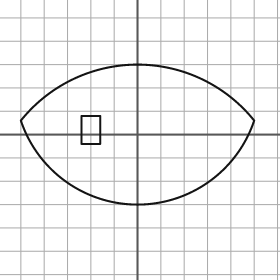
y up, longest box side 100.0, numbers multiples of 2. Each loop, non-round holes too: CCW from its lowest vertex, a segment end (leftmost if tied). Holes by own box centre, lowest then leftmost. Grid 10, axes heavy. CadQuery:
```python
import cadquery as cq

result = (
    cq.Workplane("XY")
    .moveTo(-50.0, 6.0)
    .threePointArc((0.0, -30.0), (50.0, 6.0))
    .threePointArc((0.0, 30.0), (-50.0, 6.0))
    .close()
    .moveTo(-24.0, -4.0)
    .lineTo(-16.0, -4.0)
    .lineTo(-16.0, 8.0)
    .lineTo(-24.0, 8.0)
    .close()
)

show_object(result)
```